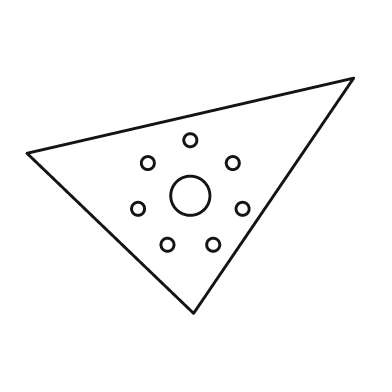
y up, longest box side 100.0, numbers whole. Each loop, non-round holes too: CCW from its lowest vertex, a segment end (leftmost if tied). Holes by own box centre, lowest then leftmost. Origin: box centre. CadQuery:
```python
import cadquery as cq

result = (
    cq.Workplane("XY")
    .moveTo(1.0, -36.0)
    .lineTo(50.0, 36.0)
    .lineTo(-50.0, 13.0)
    .close()
    .moveTo(-7.0, -15.0)
    .circle(2.0)
    .moveTo(7.0, -15.0)
    .circle(2.0)
    .moveTo(-16.0, -4.0)
    .circle(2.0)
    .moveTo(16.0, -4.0)
    .circle(2.0)
    .moveTo(0.0, 0.0)
    .circle(6.0)
    .moveTo(-13.0, 10.0)
    .circle(2.0)
    .moveTo(13.0, 10.0)
    .circle(2.0)
    .moveTo(0.0, 17.0)
    .circle(2.0)
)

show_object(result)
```